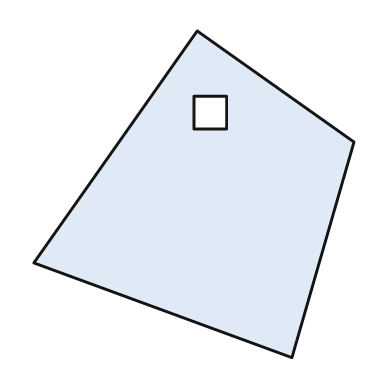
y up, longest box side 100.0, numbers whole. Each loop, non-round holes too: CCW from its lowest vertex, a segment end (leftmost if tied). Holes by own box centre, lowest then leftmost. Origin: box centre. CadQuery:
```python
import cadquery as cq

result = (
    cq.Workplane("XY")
    .moveTo(30.0, -50.0)
    .lineTo(49.0, 16.0)
    .lineTo(1.0, 50.0)
    .lineTo(-49.0, -21.0)
    .close()
    .moveTo(0.0, 20.0)
    .lineTo(10.0, 20.0)
    .lineTo(10.0, 30.0)
    .lineTo(0.0, 30.0)
    .close()
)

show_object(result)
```